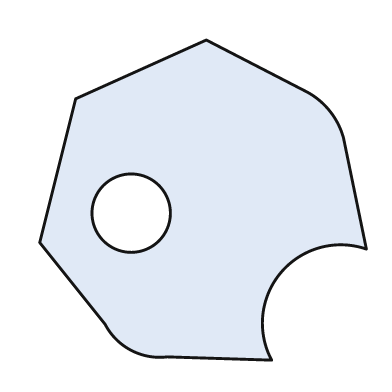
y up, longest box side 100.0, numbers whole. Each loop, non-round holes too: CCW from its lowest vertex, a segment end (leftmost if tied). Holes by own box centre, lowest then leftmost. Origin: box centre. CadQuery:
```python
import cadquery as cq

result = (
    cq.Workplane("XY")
    .moveTo(21.0, -49.0)
    .threePointArc((24.0, -22.0), (50.0, -15.0))
    .lineTo(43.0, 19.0)
    .threePointArc((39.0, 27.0), (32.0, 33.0))
    .lineTo(1.0, 49.0)
    .lineTo(-39.0, 31.0)
    .lineTo(-50.0, -13.0)
    .lineTo(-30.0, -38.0)
    .threePointArc((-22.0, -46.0), (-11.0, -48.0))
    .close()
    .moveTo(-22.0, -4.0)
    .circle(12.0)
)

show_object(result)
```